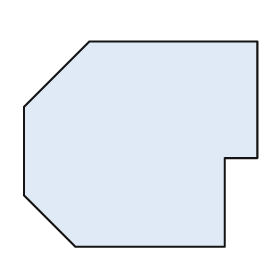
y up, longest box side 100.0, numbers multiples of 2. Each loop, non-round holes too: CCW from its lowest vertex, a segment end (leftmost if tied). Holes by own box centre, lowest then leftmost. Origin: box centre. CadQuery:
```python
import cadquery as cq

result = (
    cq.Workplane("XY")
    .moveTo(-28.0, -44.0)
    .lineTo(36.0, -44.0)
    .lineTo(36.0, -6.0)
    .lineTo(50.0, -6.0)
    .lineTo(50.0, 44.0)
    .lineTo(-22.0, 44.0)
    .lineTo(-50.0, 16.0)
    .lineTo(-50.0, -22.0)
    .close()
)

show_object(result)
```